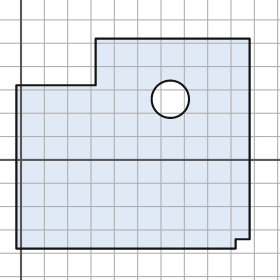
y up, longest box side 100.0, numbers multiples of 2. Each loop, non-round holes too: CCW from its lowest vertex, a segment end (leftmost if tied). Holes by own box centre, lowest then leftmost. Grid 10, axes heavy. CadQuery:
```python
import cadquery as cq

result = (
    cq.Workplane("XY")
    .moveTo(-2.0, -38.0)
    .lineTo(92.0, -38.0)
    .lineTo(92.0, -34.0)
    .lineTo(98.0, -34.0)
    .lineTo(98.0, 52.0)
    .lineTo(32.0, 52.0)
    .lineTo(32.0, 32.0)
    .lineTo(-2.0, 32.0)
    .close()
    .moveTo(64.0, 26.0)
    .circle(8.0)
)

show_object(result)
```